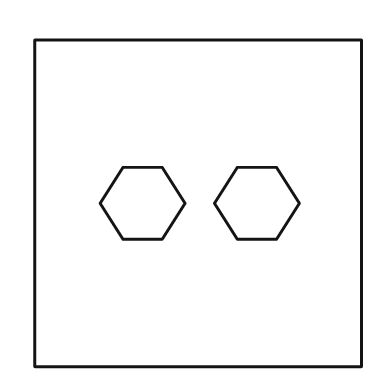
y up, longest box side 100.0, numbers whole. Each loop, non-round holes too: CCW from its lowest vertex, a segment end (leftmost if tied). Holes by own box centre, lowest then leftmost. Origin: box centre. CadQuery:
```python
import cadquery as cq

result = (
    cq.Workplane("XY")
    .moveTo(-50.0, -50.0)
    .lineTo(50.0, -50.0)
    .lineTo(50.0, 50.0)
    .lineTo(-50.0, 50.0)
    .close()
    .moveTo(-23.0, -11.0)
    .lineTo(-11.0, -11.0)
    .lineTo(-4.0, 0.0)
    .lineTo(-11.0, 11.0)
    .lineTo(-23.0, 11.0)
    .lineTo(-30.0, 0.0)
    .close()
    .moveTo(12.0, -11.0)
    .lineTo(24.0, -11.0)
    .lineTo(31.0, 0.0)
    .lineTo(24.0, 11.0)
    .lineTo(12.0, 11.0)
    .lineTo(5.0, 0.0)
    .close()
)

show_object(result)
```